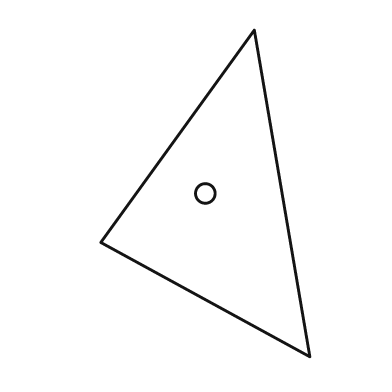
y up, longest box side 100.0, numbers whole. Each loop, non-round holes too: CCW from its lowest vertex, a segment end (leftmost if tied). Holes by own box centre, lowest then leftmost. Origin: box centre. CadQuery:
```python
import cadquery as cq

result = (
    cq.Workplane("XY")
    .moveTo(32.0, -50.0)
    .lineTo(15.0, 50.0)
    .lineTo(-32.0, -15.0)
    .close()
    .moveTo(0.0, 0.0)
    .circle(3.0)
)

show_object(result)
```